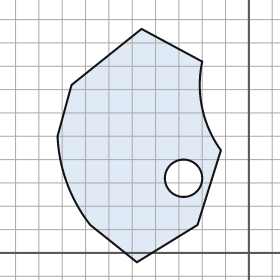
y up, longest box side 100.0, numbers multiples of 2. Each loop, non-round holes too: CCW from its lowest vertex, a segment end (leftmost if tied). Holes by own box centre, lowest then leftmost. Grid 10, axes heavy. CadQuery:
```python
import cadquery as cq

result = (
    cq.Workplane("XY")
    .moveTo(-48.0, -4.0)
    .lineTo(-22.0, 12.0)
    .lineTo(-12.0, 44.0)
    .threePointArc((-20.0, 62.0), (-20.0, 82.0))
    .lineTo(-46.0, 96.0)
    .lineTo(-76.0, 72.0)
    .lineTo(-82.0, 50.0)
    .threePointArc((-78.0, 30.0), (-68.0, 12.0))
    .close()
    .moveTo(-28.0, 32.0)
    .circle(8.0)
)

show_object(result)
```